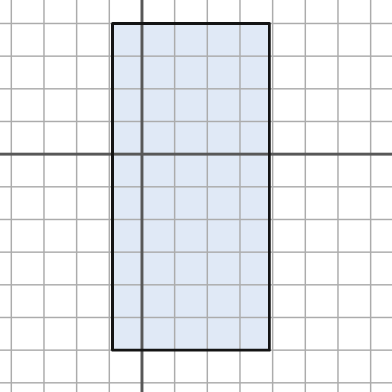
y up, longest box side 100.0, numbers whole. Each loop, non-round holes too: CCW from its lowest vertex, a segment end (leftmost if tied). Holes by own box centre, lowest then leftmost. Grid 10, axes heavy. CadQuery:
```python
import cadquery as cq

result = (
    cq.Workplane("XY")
    .moveTo(-9.0, -60.0)
    .lineTo(39.0, -60.0)
    .lineTo(39.0, 40.0)
    .lineTo(-9.0, 40.0)
    .close()
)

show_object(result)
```